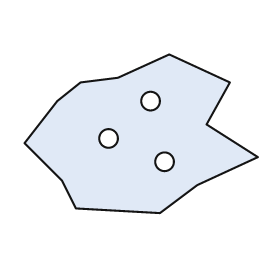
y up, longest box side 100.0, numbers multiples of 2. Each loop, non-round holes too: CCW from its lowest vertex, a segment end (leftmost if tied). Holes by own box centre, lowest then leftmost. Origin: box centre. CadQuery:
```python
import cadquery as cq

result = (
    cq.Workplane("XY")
    .moveTo(8.0, -34.0)
    .lineTo(24.0, -22.0)
    .lineTo(50.0, -10.0)
    .lineTo(28.0, 4.0)
    .lineTo(38.0, 22.0)
    .lineTo(12.0, 34.0)
    .lineTo(-10.0, 24.0)
    .lineTo(-26.0, 22.0)
    .lineTo(-36.0, 14.0)
    .lineTo(-50.0, -4.0)
    .lineTo(-34.0, -20.0)
    .lineTo(-28.0, -32.0)
    .close()
    .moveTo(10.0, -12.0)
    .circle(4.0)
    .moveTo(-14.0, -2.0)
    .circle(4.0)
    .moveTo(4.0, 14.0)
    .circle(4.0)
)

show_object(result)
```